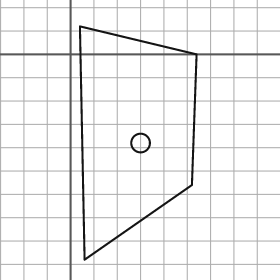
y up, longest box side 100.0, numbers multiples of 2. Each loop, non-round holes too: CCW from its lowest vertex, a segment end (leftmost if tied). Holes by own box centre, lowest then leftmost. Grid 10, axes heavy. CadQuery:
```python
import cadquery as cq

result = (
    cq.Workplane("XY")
    .moveTo(6.0, -88.0)
    .lineTo(52.0, -56.0)
    .lineTo(54.0, 0.0)
    .lineTo(4.0, 12.0)
    .close()
    .moveTo(30.0, -38.0)
    .circle(4.0)
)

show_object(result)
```